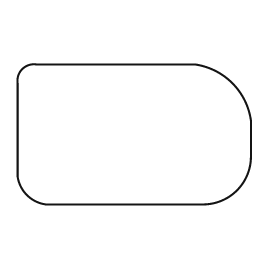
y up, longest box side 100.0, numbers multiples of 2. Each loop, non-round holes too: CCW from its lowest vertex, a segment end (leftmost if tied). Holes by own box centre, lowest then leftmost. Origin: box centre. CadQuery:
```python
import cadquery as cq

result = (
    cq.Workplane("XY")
    .moveTo(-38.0, -30.0)
    .lineTo(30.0, -30.0)
    .threePointArc((44.0, -24.0), (50.0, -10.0))
    .lineTo(50.0, 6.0)
    .threePointArc((42.0, 22.0), (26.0, 30.0))
    .lineTo(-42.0, 30.0)
    .threePointArc((-48.0, 28.0), (-50.0, 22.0))
    .lineTo(-50.0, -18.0)
    .threePointArc((-46.0, -26.0), (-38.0, -30.0))
    .close()
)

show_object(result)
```